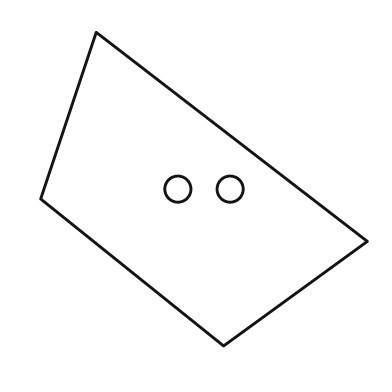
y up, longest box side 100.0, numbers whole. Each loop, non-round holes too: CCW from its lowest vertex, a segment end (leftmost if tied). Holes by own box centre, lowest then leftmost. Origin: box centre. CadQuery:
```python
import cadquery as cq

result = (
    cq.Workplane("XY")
    .moveTo(6.0, -48.0)
    .lineTo(50.0, -16.0)
    .lineTo(-33.0, 48.0)
    .lineTo(-50.0, -3.0)
    .close()
    .moveTo(-8.0, 0.0)
    .circle(4.0)
    .moveTo(8.0, 0.0)
    .circle(4.0)
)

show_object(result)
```